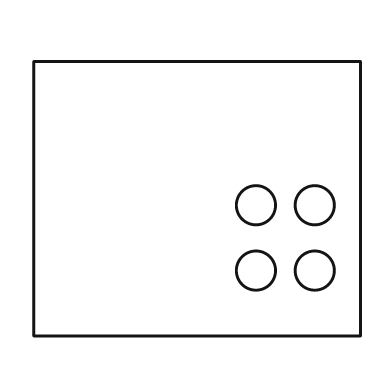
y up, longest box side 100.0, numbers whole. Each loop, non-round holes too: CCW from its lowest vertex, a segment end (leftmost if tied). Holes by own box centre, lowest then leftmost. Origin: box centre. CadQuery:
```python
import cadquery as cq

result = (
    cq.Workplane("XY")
    .moveTo(-50.0, -42.0)
    .lineTo(50.0, -42.0)
    .lineTo(50.0, 42.0)
    .lineTo(-50.0, 42.0)
    .close()
    .moveTo(18.0, -22.0)
    .circle(6.0)
    .moveTo(36.0, -22.0)
    .circle(6.0)
    .moveTo(18.0, -2.0)
    .circle(6.0)
    .moveTo(36.0, -2.0)
    .circle(6.0)
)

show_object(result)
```